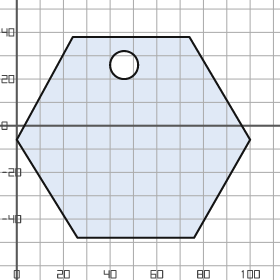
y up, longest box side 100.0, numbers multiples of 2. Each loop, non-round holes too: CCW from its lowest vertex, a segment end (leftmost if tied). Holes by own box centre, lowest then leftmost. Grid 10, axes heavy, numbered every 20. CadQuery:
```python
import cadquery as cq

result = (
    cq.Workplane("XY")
    .moveTo(26.0, -48.0)
    .lineTo(76.0, -48.0)
    .lineTo(100.0, -6.0)
    .lineTo(74.0, 38.0)
    .lineTo(24.0, 38.0)
    .lineTo(0.0, -6.0)
    .close()
    .moveTo(46.0, 26.0)
    .circle(6.0)
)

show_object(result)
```